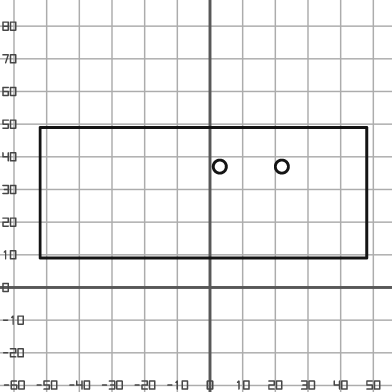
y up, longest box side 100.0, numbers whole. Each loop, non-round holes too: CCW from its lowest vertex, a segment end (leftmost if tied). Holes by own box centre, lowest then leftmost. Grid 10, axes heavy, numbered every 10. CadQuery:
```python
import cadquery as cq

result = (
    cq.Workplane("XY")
    .moveTo(-52.0, 9.0)
    .lineTo(48.0, 9.0)
    .lineTo(48.0, 49.0)
    .lineTo(-52.0, 49.0)
    .close()
    .moveTo(3.0, 37.0)
    .circle(2.0)
    .moveTo(22.0, 37.0)
    .circle(2.0)
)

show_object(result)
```